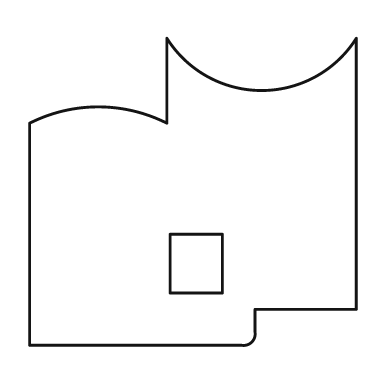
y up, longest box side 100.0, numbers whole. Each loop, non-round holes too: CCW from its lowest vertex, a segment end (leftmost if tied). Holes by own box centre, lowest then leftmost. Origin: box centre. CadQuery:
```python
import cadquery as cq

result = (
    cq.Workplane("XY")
    .moveTo(-50.0, -47.0)
    .lineTo(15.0, -47.0)
    .threePointArc((18.0, -46.0), (19.0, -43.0))
    .lineTo(19.0, -36.0)
    .lineTo(50.0, -36.0)
    .lineTo(50.0, 47.0)
    .threePointArc((21.0, 31.0), (-8.0, 47.0))
    .lineTo(-8.0, 21.0)
    .threePointArc((-29.0, 26.0), (-50.0, 21.0))
    .close()
    .moveTo(-7.0, -31.0)
    .lineTo(9.0, -31.0)
    .lineTo(9.0, -13.0)
    .lineTo(-7.0, -13.0)
    .close()
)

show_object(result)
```